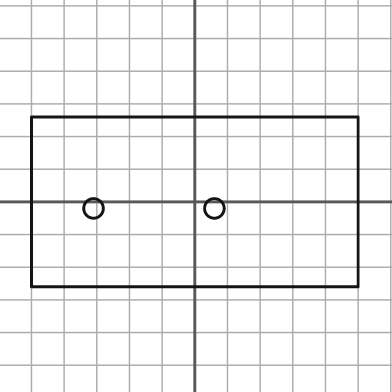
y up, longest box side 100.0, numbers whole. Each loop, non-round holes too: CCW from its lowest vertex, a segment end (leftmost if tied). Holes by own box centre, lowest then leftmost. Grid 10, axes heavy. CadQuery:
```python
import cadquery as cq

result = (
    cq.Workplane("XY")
    .moveTo(-50.0, -26.0)
    .lineTo(50.0, -26.0)
    .lineTo(50.0, 26.0)
    .lineTo(-50.0, 26.0)
    .close()
    .moveTo(-31.0, -2.0)
    .circle(3.0)
    .moveTo(6.0, -2.0)
    .circle(3.0)
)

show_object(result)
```